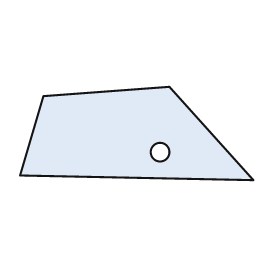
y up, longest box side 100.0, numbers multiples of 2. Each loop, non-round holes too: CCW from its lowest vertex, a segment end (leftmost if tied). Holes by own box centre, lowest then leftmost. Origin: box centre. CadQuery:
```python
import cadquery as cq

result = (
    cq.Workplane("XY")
    .moveTo(50.0, -20.0)
    .lineTo(14.0, 20.0)
    .lineTo(-40.0, 16.0)
    .lineTo(-50.0, -18.0)
    .close()
    .moveTo(10.0, -8.0)
    .circle(4.0)
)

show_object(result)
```